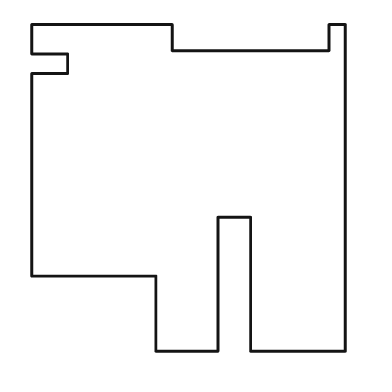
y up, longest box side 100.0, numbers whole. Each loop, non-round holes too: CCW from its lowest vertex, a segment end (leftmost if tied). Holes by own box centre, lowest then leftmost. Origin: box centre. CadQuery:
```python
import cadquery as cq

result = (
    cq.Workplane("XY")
    .moveTo(-10.0, -50.0)
    .lineTo(9.0, -50.0)
    .lineTo(9.0, -9.0)
    .lineTo(19.0, -9.0)
    .lineTo(19.0, -50.0)
    .lineTo(48.0, -50.0)
    .lineTo(48.0, 50.0)
    .lineTo(43.0, 50.0)
    .lineTo(43.0, 42.0)
    .lineTo(-5.0, 42.0)
    .lineTo(-5.0, 50.0)
    .lineTo(-48.0, 50.0)
    .lineTo(-48.0, 41.0)
    .lineTo(-37.0, 41.0)
    .lineTo(-37.0, 35.0)
    .lineTo(-48.0, 35.0)
    .lineTo(-48.0, -27.0)
    .lineTo(-10.0, -27.0)
    .close()
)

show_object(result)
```